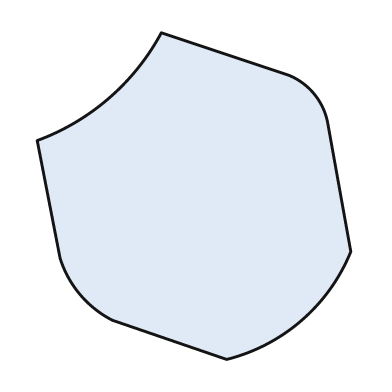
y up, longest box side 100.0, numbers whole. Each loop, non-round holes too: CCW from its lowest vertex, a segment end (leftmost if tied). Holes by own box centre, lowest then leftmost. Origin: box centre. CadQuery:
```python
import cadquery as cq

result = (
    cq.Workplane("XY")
    .moveTo(10.0, -50.0)
    .threePointArc((33.0, -38.0), (48.0, -17.0))
    .lineTo(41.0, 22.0)
    .threePointArc((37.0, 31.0), (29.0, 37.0))
    .lineTo(-10.0, 50.0)
    .threePointArc((-26.0, 30.0), (-48.0, 17.0))
    .lineTo(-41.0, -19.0)
    .threePointArc((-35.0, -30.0), (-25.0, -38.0))
    .close()
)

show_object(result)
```